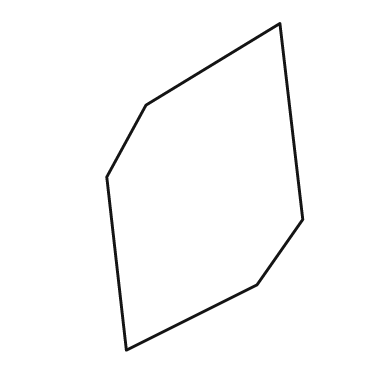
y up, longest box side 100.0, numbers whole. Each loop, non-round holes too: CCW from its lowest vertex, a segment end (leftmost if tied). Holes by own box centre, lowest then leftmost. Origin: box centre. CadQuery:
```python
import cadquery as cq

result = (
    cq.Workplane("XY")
    .moveTo(-24.0, -50.0)
    .lineTo(16.0, -30.0)
    .lineTo(30.0, -10.0)
    .lineTo(23.0, 50.0)
    .lineTo(-18.0, 25.0)
    .lineTo(-30.0, 3.0)
    .close()
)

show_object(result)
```